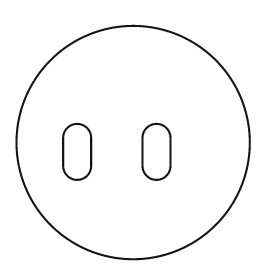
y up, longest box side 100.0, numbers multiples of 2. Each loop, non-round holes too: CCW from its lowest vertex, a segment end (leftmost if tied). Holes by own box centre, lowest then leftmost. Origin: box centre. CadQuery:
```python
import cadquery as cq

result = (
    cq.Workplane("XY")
    .moveTo(0.0, 0.0)
    .circle(50.0)
    .moveTo(-30.0, -10.0)
    .threePointArc((-24.0, -16.0), (-18.0, -10.0))
    .lineTo(-18.0, 2.0)
    .threePointArc((-24.0, 8.0), (-30.0, 2.0))
    .close()
    .moveTo(4.0, -10.0)
    .threePointArc((10.0, -16.0), (16.0, -10.0))
    .lineTo(16.0, 2.0)
    .threePointArc((10.0, 8.0), (4.0, 2.0))
    .close()
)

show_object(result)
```